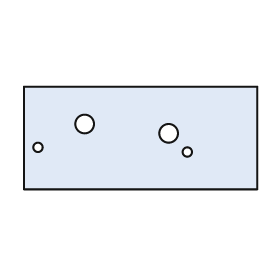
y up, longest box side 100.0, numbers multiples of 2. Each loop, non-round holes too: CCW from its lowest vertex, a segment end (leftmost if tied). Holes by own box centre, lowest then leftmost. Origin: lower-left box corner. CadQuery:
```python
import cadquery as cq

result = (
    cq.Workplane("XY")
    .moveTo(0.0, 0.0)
    .lineTo(100.0, 0.0)
    .lineTo(100.0, 44.0)
    .lineTo(0.0, 44.0)
    .close()
    .moveTo(70.0, 16.0)
    .circle(2.0)
    .moveTo(6.0, 18.0)
    .circle(2.0)
    .moveTo(62.0, 24.0)
    .circle(4.0)
    .moveTo(26.0, 28.0)
    .circle(4.0)
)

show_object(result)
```